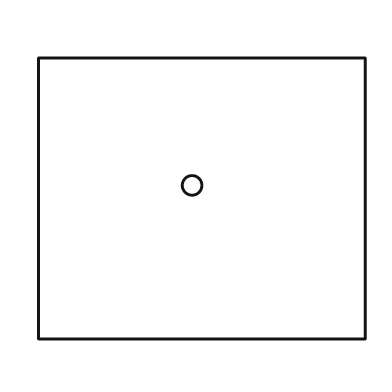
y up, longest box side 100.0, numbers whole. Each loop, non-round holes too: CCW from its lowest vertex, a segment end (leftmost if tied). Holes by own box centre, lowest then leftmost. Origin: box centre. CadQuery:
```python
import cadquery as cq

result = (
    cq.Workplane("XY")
    .moveTo(-50.0, -43.0)
    .lineTo(50.0, -43.0)
    .lineTo(50.0, 43.0)
    .lineTo(-50.0, 43.0)
    .close()
    .moveTo(-3.0, 4.0)
    .circle(3.0)
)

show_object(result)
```